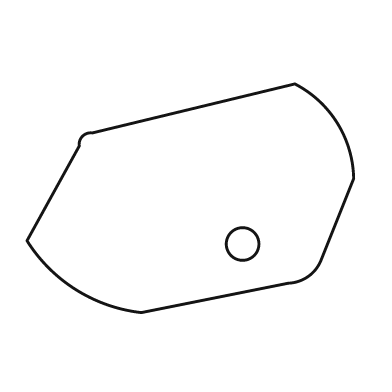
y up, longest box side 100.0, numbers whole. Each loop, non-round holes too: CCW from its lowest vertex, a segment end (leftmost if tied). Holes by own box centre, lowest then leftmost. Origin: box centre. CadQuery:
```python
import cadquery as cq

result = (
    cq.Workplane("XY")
    .moveTo(-15.0, -35.0)
    .lineTo(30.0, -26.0)
    .threePointArc((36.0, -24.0), (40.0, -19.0))
    .lineTo(50.0, 6.0)
    .threePointArc((45.0, 23.0), (32.0, 35.0))
    .lineTo(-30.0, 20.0)
    .threePointArc((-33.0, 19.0), (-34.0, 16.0))
    .lineTo(-50.0, -13.0)
    .threePointArc((-35.0, -28.0), (-15.0, -35.0))
    .close()
    .moveTo(16.0, -14.0)
    .circle(5.0)
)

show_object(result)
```